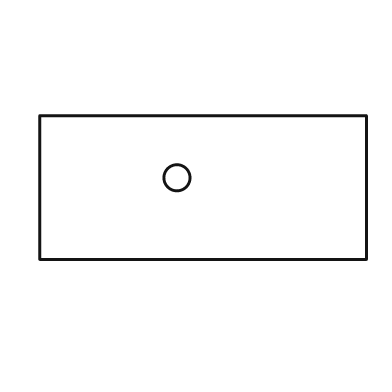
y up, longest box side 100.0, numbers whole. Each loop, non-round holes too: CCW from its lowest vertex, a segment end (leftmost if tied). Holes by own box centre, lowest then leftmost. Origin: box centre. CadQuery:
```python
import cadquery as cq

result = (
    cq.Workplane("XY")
    .moveTo(-50.0, -22.0)
    .lineTo(50.0, -22.0)
    .lineTo(50.0, 22.0)
    .lineTo(-50.0, 22.0)
    .close()
    .moveTo(-8.0, 3.0)
    .circle(4.0)
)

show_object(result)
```